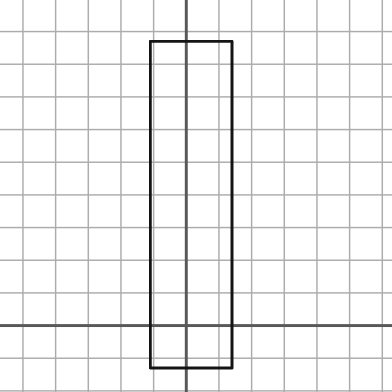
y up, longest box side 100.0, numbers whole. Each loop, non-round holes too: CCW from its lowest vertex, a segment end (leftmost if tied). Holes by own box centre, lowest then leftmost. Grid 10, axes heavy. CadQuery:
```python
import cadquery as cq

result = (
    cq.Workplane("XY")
    .moveTo(-11.0, -13.0)
    .lineTo(14.0, -13.0)
    .lineTo(14.0, 87.0)
    .lineTo(-11.0, 87.0)
    .close()
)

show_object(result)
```